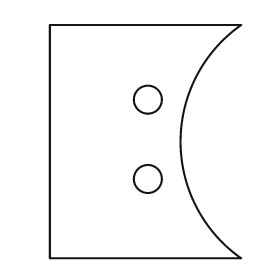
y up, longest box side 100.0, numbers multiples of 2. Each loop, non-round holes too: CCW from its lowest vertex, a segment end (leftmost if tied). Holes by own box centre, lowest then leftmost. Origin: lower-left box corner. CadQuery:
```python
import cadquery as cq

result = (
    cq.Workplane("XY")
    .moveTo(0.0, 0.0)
    .lineTo(82.0, 0.0)
    .threePointArc((56.0, 50.0), (82.0, 100.0))
    .lineTo(0.0, 100.0)
    .close()
    .moveTo(42.0, 34.0)
    .circle(6.0)
    .moveTo(42.0, 68.0)
    .circle(6.0)
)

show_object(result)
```